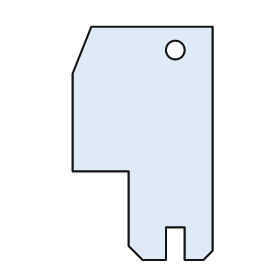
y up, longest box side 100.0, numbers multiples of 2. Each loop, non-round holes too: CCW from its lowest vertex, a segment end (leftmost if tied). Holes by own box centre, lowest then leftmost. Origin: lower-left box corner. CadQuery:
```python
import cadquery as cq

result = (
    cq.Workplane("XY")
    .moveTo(30.0, 0.0)
    .lineTo(40.0, 0.0)
    .lineTo(40.0, 14.0)
    .lineTo(48.0, 14.0)
    .lineTo(48.0, 0.0)
    .lineTo(56.0, 0.0)
    .lineTo(60.0, 4.0)
    .lineTo(60.0, 100.0)
    .lineTo(8.0, 100.0)
    .lineTo(0.0, 80.0)
    .lineTo(0.0, 38.0)
    .lineTo(24.0, 38.0)
    .lineTo(24.0, 6.0)
    .close()
    .moveTo(44.0, 90.0)
    .circle(4.0)
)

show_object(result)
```